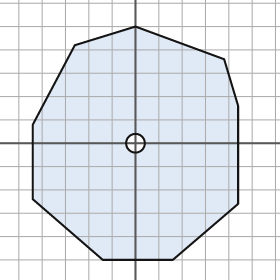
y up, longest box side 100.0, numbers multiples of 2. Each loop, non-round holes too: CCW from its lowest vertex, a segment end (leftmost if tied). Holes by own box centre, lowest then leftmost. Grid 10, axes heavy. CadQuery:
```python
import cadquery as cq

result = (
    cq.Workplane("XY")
    .moveTo(-14.0, -50.0)
    .lineTo(16.0, -50.0)
    .lineTo(44.0, -26.0)
    .lineTo(44.0, 16.0)
    .lineTo(38.0, 36.0)
    .lineTo(0.0, 50.0)
    .lineTo(-26.0, 42.0)
    .lineTo(-44.0, 8.0)
    .lineTo(-44.0, -24.0)
    .close()
    .moveTo(0.0, 0.0)
    .circle(4.0)
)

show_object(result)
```